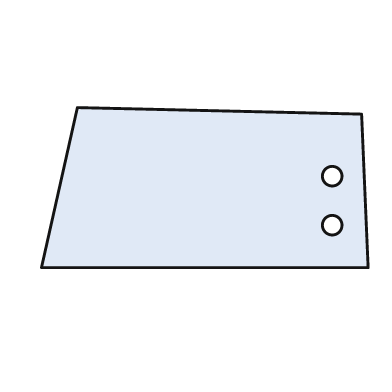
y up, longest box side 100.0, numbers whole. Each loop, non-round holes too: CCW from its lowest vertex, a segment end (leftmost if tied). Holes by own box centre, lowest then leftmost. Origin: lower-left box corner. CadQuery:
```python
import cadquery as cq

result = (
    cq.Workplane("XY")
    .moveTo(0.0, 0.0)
    .lineTo(100.0, 0.0)
    .lineTo(98.0, 47.0)
    .lineTo(11.0, 49.0)
    .close()
    .moveTo(89.0, 13.0)
    .circle(3.0)
    .moveTo(89.0, 28.0)
    .circle(3.0)
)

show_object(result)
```